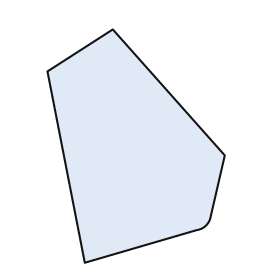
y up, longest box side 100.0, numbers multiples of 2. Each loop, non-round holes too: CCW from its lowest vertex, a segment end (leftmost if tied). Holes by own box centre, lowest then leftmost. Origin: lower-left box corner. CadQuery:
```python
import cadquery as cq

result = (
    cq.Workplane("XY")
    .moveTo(16.0, 0.0)
    .lineTo(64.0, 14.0)
    .threePointArc((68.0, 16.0), (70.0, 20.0))
    .lineTo(76.0, 46.0)
    .lineTo(28.0, 100.0)
    .lineTo(0.0, 82.0)
    .close()
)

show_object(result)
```